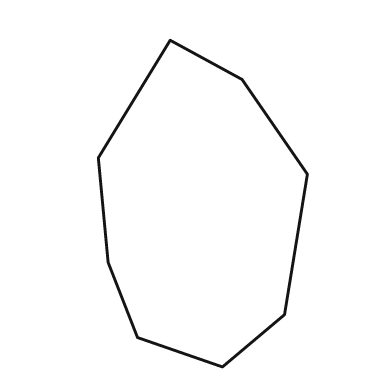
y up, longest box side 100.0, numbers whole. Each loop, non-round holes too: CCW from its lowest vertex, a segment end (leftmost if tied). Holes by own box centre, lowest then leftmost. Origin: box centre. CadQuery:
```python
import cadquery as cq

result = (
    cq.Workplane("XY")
    .moveTo(6.0, -50.0)
    .lineTo(25.0, -34.0)
    .lineTo(32.0, 9.0)
    .lineTo(12.0, 38.0)
    .lineTo(-10.0, 50.0)
    .lineTo(-32.0, 14.0)
    .lineTo(-29.0, -18.0)
    .lineTo(-20.0, -41.0)
    .close()
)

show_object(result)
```